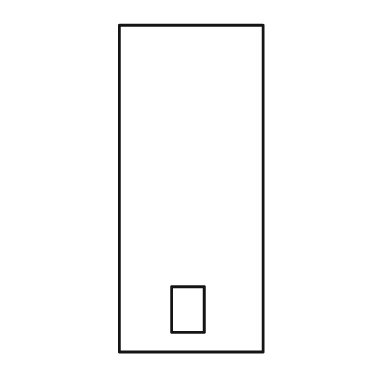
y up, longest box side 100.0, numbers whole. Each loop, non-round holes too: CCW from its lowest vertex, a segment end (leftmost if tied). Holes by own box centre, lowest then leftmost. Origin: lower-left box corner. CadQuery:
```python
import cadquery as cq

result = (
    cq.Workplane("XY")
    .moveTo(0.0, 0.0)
    .lineTo(44.0, 0.0)
    .lineTo(44.0, 100.0)
    .lineTo(0.0, 100.0)
    .close()
    .moveTo(16.0, 6.0)
    .lineTo(26.0, 6.0)
    .lineTo(26.0, 20.0)
    .lineTo(16.0, 20.0)
    .close()
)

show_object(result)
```